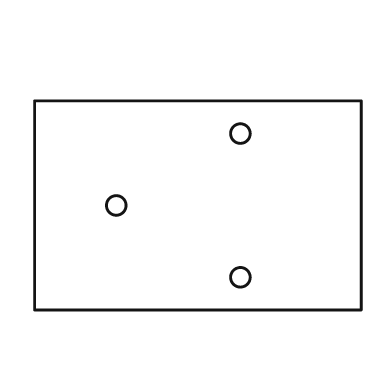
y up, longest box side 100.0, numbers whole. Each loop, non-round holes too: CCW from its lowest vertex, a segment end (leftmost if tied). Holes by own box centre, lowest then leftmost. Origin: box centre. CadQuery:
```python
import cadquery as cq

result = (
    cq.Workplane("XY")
    .moveTo(-50.0, -32.0)
    .lineTo(50.0, -32.0)
    .lineTo(50.0, 32.0)
    .lineTo(-50.0, 32.0)
    .close()
    .moveTo(13.0, -22.0)
    .circle(3.0)
    .moveTo(-25.0, 0.0)
    .circle(3.0)
    .moveTo(13.0, 22.0)
    .circle(3.0)
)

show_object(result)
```